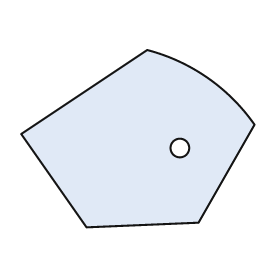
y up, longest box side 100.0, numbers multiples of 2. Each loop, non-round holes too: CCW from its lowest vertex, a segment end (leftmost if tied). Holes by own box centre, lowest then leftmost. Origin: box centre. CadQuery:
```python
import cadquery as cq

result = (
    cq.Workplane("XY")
    .moveTo(-22.0, -38.0)
    .lineTo(26.0, -36.0)
    .lineTo(50.0, 6.0)
    .threePointArc((30.0, 26.0), (4.0, 38.0))
    .lineTo(-50.0, 2.0)
    .close()
    .moveTo(18.0, -4.0)
    .circle(4.0)
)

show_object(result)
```